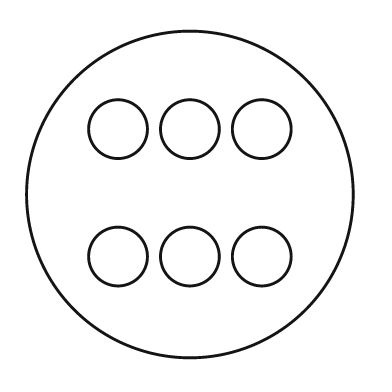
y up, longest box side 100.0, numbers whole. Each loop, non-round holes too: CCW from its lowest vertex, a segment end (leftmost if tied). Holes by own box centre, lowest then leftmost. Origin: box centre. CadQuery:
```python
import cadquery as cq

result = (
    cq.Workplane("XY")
    .moveTo(0.0, 0.0)
    .circle(50.0)
    .moveTo(-22.0, -19.0)
    .circle(9.0)
    .moveTo(0.0, -19.0)
    .circle(9.0)
    .moveTo(22.0, -19.0)
    .circle(9.0)
    .moveTo(-22.0, 20.0)
    .circle(9.0)
    .moveTo(0.0, 20.0)
    .circle(9.0)
    .moveTo(22.0, 20.0)
    .circle(9.0)
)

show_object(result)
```